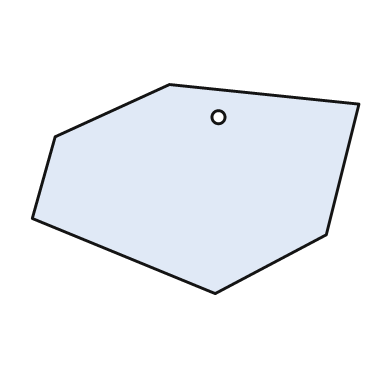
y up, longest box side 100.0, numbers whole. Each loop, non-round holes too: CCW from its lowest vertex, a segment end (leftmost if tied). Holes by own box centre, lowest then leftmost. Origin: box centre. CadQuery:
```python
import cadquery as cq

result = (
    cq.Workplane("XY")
    .moveTo(6.0, -32.0)
    .lineTo(40.0, -14.0)
    .lineTo(50.0, 26.0)
    .lineTo(-8.0, 32.0)
    .lineTo(-43.0, 16.0)
    .lineTo(-50.0, -9.0)
    .close()
    .moveTo(7.0, 22.0)
    .circle(2.0)
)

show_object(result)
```